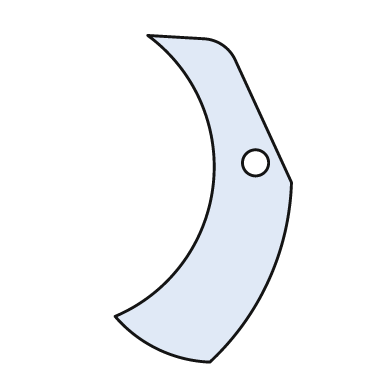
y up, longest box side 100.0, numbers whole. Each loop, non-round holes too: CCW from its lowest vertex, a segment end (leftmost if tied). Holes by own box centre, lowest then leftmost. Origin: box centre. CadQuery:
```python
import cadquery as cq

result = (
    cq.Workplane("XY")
    .moveTo(2.0, -50.0)
    .threePointArc((20.0, -25.0), (27.0, 5.0))
    .lineTo(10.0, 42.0)
    .threePointArc((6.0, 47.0), (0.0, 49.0))
    .lineTo(-17.0, 50.0)
    .threePointArc((3.0, 4.0), (-27.0, -36.0))
    .threePointArc((-14.0, -46.0), (2.0, -50.0))
    .close()
    .moveTo(16.0, 11.0)
    .circle(4.0)
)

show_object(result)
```